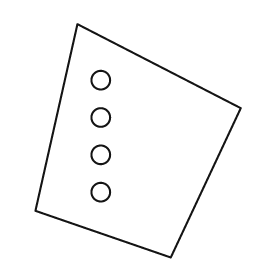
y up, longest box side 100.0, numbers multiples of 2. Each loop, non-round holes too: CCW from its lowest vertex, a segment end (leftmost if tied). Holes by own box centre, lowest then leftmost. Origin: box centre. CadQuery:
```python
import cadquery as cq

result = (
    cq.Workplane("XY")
    .moveTo(14.0, -50.0)
    .lineTo(44.0, 14.0)
    .lineTo(-26.0, 50.0)
    .lineTo(-44.0, -30.0)
    .close()
    .moveTo(-16.0, -22.0)
    .circle(4.0)
    .moveTo(-16.0, -6.0)
    .circle(4.0)
    .moveTo(-16.0, 10.0)
    .circle(4.0)
    .moveTo(-16.0, 26.0)
    .circle(4.0)
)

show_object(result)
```